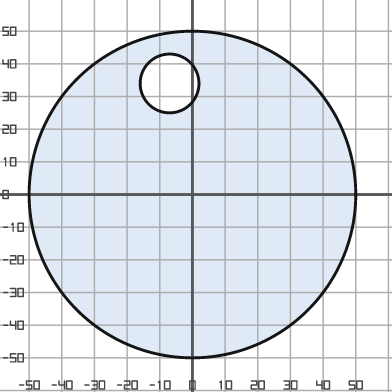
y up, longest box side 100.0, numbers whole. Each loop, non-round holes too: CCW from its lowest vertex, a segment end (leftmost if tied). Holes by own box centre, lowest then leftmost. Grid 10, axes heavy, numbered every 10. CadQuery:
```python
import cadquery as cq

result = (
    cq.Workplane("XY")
    .moveTo(0.0, 0.0)
    .circle(50.0)
    .moveTo(-7.0, 34.0)
    .circle(9.0)
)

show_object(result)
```